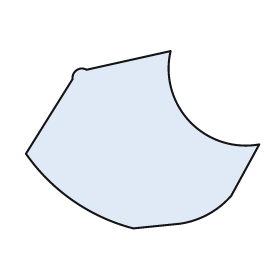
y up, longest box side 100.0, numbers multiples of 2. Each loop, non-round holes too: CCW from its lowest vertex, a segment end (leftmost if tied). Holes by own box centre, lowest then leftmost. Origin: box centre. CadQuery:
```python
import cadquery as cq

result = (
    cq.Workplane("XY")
    .moveTo(-4.0, -38.0)
    .lineTo(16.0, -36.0)
    .threePointArc((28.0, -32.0), (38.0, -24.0))
    .lineTo(50.0, -2.0)
    .threePointArc((20.0, 8.0), (12.0, 38.0))
    .lineTo(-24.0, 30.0)
    .threePointArc((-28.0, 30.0), (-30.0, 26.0))
    .lineTo(-50.0, -6.0)
    .threePointArc((-30.0, -26.0), (-4.0, -38.0))
    .close()
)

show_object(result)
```